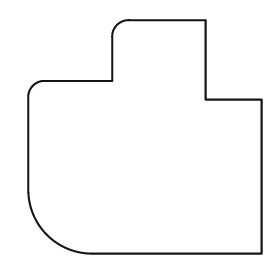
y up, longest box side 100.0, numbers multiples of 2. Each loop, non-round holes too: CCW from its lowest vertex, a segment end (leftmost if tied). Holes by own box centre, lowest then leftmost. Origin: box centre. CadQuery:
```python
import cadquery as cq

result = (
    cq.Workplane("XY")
    .moveTo(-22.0, -50.0)
    .lineTo(50.0, -50.0)
    .lineTo(50.0, 16.0)
    .lineTo(26.0, 16.0)
    .lineTo(26.0, 50.0)
    .lineTo(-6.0, 50.0)
    .threePointArc((-12.0, 48.0), (-14.0, 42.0))
    .lineTo(-14.0, 24.0)
    .lineTo(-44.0, 24.0)
    .threePointArc((-48.0, 22.0), (-50.0, 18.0))
    .lineTo(-50.0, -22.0)
    .threePointArc((-42.0, -42.0), (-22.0, -50.0))
    .close()
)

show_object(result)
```